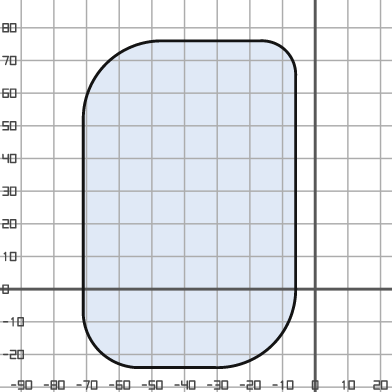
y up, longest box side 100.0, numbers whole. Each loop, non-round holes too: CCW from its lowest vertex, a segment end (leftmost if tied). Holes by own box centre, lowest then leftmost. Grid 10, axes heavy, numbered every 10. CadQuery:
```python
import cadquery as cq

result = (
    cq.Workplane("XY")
    .moveTo(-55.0, -24.0)
    .lineTo(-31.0, -24.0)
    .threePointArc((-13.0, -17.0), (-6.0, 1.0))
    .lineTo(-6.0, 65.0)
    .threePointArc((-9.0, 73.0), (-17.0, 76.0))
    .lineTo(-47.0, 76.0)
    .threePointArc((-64.0, 69.0), (-71.0, 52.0))
    .lineTo(-71.0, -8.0)
    .threePointArc((-66.0, -19.0), (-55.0, -24.0))
    .close()
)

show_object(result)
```